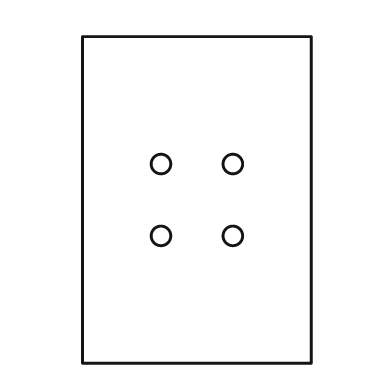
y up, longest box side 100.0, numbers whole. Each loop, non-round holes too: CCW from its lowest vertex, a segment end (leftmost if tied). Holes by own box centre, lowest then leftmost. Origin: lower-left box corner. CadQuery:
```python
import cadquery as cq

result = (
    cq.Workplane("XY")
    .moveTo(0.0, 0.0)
    .lineTo(70.0, 0.0)
    .lineTo(70.0, 100.0)
    .lineTo(0.0, 100.0)
    .close()
    .moveTo(24.0, 39.0)
    .circle(3.0)
    .moveTo(46.0, 39.0)
    .circle(3.0)
    .moveTo(24.0, 61.0)
    .circle(3.0)
    .moveTo(46.0, 61.0)
    .circle(3.0)
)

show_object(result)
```